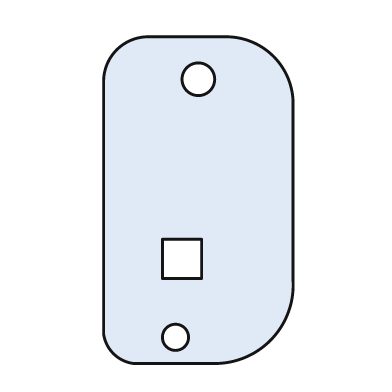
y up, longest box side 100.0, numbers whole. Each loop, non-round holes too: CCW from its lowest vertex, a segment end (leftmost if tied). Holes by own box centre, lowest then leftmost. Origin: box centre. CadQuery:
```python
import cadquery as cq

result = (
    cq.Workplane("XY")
    .moveTo(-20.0, -50.0)
    .lineTo(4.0, -50.0)
    .threePointArc((22.0, -43.0), (29.0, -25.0))
    .lineTo(29.0, 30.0)
    .threePointArc((23.0, 44.0), (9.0, 50.0))
    .lineTo(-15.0, 50.0)
    .threePointArc((-25.0, 46.0), (-29.0, 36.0))
    .lineTo(-29.0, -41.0)
    .threePointArc((-26.0, -47.0), (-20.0, -50.0))
    .close()
    .moveTo(-7.0, -42.0)
    .circle(4.0)
    .moveTo(-11.0, -24.0)
    .lineTo(1.0, -24.0)
    .lineTo(1.0, -12.0)
    .lineTo(-11.0, -12.0)
    .close()
    .moveTo(0.0, 37.0)
    .circle(5.0)
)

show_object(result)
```